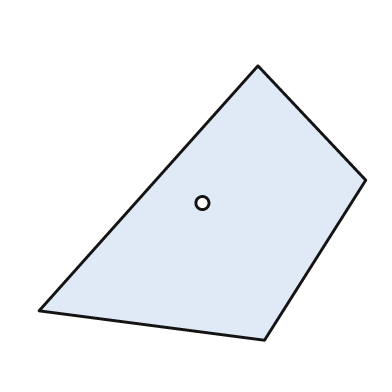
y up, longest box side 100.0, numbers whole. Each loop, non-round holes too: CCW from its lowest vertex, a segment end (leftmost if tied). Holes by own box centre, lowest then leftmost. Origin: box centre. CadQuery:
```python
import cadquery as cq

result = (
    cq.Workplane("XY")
    .moveTo(19.0, -42.0)
    .lineTo(50.0, 7.0)
    .lineTo(17.0, 42.0)
    .lineTo(-50.0, -33.0)
    .close()
    .moveTo(0.0, 0.0)
    .circle(2.0)
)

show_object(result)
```